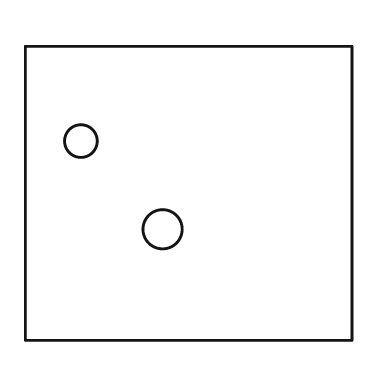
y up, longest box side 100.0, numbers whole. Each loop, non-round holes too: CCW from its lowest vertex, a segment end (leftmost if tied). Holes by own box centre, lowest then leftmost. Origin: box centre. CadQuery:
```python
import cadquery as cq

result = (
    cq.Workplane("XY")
    .moveTo(-50.0, -45.0)
    .lineTo(50.0, -45.0)
    .lineTo(50.0, 45.0)
    .lineTo(-50.0, 45.0)
    .close()
    .moveTo(-8.0, -11.0)
    .circle(6.0)
    .moveTo(-33.0, 16.0)
    .circle(5.0)
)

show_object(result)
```